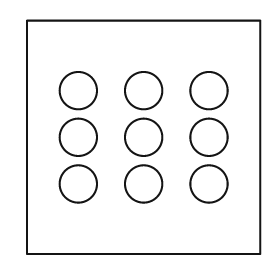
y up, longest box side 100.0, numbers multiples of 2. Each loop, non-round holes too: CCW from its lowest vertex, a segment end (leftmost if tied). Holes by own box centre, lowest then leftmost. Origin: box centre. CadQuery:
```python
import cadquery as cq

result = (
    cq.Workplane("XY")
    .moveTo(-50.0, -50.0)
    .lineTo(50.0, -50.0)
    .lineTo(50.0, 50.0)
    .lineTo(-50.0, 50.0)
    .close()
    .moveTo(-28.0, -20.0)
    .circle(8.0)
    .moveTo(0.0, -20.0)
    .circle(8.0)
    .moveTo(28.0, -20.0)
    .circle(8.0)
    .moveTo(-28.0, 0.0)
    .circle(8.0)
    .moveTo(0.0, 0.0)
    .circle(8.0)
    .moveTo(28.0, 0.0)
    .circle(8.0)
    .moveTo(-28.0, 20.0)
    .circle(8.0)
    .moveTo(0.0, 20.0)
    .circle(8.0)
    .moveTo(28.0, 20.0)
    .circle(8.0)
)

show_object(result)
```